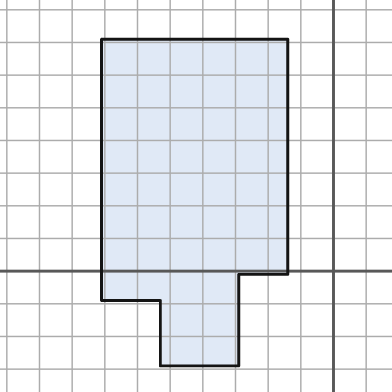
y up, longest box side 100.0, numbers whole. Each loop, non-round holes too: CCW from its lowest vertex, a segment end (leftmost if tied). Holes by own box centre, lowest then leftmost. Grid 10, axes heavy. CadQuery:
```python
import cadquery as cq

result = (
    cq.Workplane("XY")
    .moveTo(-53.0, -29.0)
    .lineTo(-29.0, -29.0)
    .lineTo(-29.0, -1.0)
    .lineTo(-14.0, -1.0)
    .lineTo(-14.0, 71.0)
    .lineTo(-71.0, 71.0)
    .lineTo(-71.0, -9.0)
    .lineTo(-53.0, -9.0)
    .close()
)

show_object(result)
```